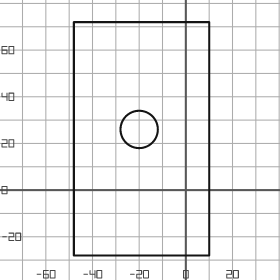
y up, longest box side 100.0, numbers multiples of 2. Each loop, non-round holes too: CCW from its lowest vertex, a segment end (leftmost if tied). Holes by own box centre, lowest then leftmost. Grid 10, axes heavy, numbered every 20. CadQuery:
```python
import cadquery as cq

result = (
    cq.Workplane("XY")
    .moveTo(-48.0, -28.0)
    .lineTo(10.0, -28.0)
    .lineTo(10.0, 72.0)
    .lineTo(-48.0, 72.0)
    .close()
    .moveTo(-20.0, 26.0)
    .circle(8.0)
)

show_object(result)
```